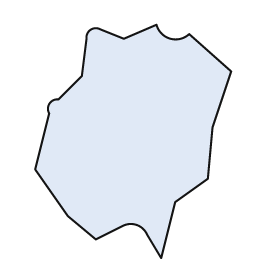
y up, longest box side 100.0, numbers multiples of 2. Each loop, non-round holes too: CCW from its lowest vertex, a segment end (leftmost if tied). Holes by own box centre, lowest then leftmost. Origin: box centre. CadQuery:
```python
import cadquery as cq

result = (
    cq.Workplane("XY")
    .moveTo(12.0, -50.0)
    .lineTo(18.0, -26.0)
    .lineTo(32.0, -16.0)
    .lineTo(34.0, 6.0)
    .lineTo(42.0, 30.0)
    .lineTo(24.0, 46.0)
    .threePointArc((16.0, 44.0), (10.0, 50.0))
    .lineTo(-4.0, 44.0)
    .lineTo(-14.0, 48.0)
    .threePointArc((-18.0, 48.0), (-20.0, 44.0))
    .lineTo(-22.0, 28.0)
    .lineTo(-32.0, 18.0)
    .threePointArc((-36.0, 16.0), (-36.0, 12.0))
    .lineTo(-42.0, -12.0)
    .lineTo(-28.0, -32.0)
    .lineTo(-16.0, -42.0)
    .lineTo(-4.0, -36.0)
    .threePointArc((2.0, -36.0), (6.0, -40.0))
    .close()
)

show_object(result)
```